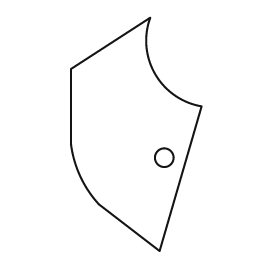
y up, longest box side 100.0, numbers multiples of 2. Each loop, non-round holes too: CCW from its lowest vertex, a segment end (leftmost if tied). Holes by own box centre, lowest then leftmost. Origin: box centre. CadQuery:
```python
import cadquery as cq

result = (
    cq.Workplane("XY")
    .moveTo(10.0, -50.0)
    .lineTo(28.0, 12.0)
    .threePointArc((8.0, 26.0), (6.0, 50.0))
    .lineTo(-28.0, 28.0)
    .lineTo(-28.0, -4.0)
    .threePointArc((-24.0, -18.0), (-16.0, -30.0))
    .close()
    .moveTo(12.0, -10.0)
    .circle(4.0)
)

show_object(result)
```